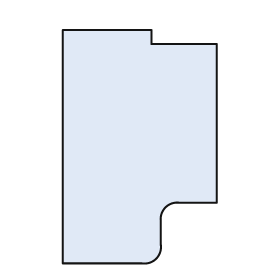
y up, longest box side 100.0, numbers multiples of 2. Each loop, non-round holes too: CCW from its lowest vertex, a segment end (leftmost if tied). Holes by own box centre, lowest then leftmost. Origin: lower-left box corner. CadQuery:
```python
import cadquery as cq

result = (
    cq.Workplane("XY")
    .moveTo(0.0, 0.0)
    .lineTo(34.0, 0.0)
    .threePointArc((40.0, 2.0), (42.0, 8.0))
    .lineTo(42.0, 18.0)
    .threePointArc((44.0, 24.0), (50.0, 26.0))
    .lineTo(66.0, 26.0)
    .lineTo(66.0, 94.0)
    .lineTo(38.0, 94.0)
    .lineTo(38.0, 100.0)
    .lineTo(0.0, 100.0)
    .close()
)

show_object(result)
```